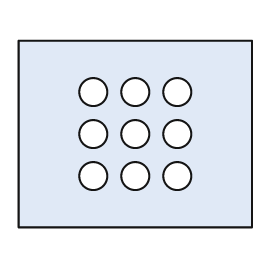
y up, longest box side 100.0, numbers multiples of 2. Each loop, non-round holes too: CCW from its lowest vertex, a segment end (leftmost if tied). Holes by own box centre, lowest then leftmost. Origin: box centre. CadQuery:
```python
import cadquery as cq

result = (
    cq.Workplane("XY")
    .moveTo(-50.0, -40.0)
    .lineTo(50.0, -40.0)
    .lineTo(50.0, 40.0)
    .lineTo(-50.0, 40.0)
    .close()
    .moveTo(-18.0, -18.0)
    .circle(6.0)
    .moveTo(0.0, -18.0)
    .circle(6.0)
    .moveTo(18.0, -18.0)
    .circle(6.0)
    .moveTo(-18.0, 0.0)
    .circle(6.0)
    .moveTo(0.0, 0.0)
    .circle(6.0)
    .moveTo(18.0, 0.0)
    .circle(6.0)
    .moveTo(-18.0, 18.0)
    .circle(6.0)
    .moveTo(0.0, 18.0)
    .circle(6.0)
    .moveTo(18.0, 18.0)
    .circle(6.0)
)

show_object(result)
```